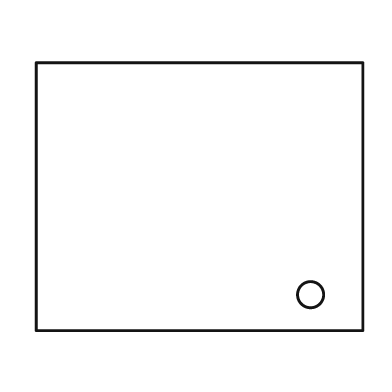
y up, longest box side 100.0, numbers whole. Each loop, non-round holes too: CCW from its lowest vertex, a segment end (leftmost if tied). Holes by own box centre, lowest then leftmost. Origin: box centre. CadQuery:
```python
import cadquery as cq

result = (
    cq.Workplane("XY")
    .moveTo(-50.0, -41.0)
    .lineTo(50.0, -41.0)
    .lineTo(50.0, 41.0)
    .lineTo(-50.0, 41.0)
    .close()
    .moveTo(34.0, -30.0)
    .circle(4.0)
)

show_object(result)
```